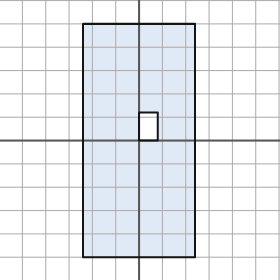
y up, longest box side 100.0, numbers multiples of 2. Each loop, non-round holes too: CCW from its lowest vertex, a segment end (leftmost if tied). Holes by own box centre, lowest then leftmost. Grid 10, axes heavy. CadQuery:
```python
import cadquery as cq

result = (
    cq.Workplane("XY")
    .moveTo(-24.0, -50.0)
    .lineTo(24.0, -50.0)
    .lineTo(24.0, 50.0)
    .lineTo(-24.0, 50.0)
    .close()
    .moveTo(0.0, 0.0)
    .lineTo(8.0, 0.0)
    .lineTo(8.0, 12.0)
    .lineTo(0.0, 12.0)
    .close()
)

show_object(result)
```